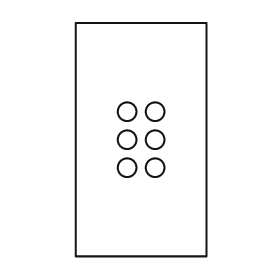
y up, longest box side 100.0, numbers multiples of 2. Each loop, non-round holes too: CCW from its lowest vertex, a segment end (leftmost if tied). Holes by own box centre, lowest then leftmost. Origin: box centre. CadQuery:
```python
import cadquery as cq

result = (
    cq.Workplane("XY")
    .moveTo(-28.0, -50.0)
    .lineTo(28.0, -50.0)
    .lineTo(28.0, 50.0)
    .lineTo(-28.0, 50.0)
    .close()
    .moveTo(-6.0, -12.0)
    .circle(4.0)
    .moveTo(6.0, -12.0)
    .circle(4.0)
    .moveTo(-6.0, 0.0)
    .circle(4.0)
    .moveTo(6.0, 0.0)
    .circle(4.0)
    .moveTo(-6.0, 12.0)
    .circle(4.0)
    .moveTo(6.0, 12.0)
    .circle(4.0)
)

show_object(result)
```